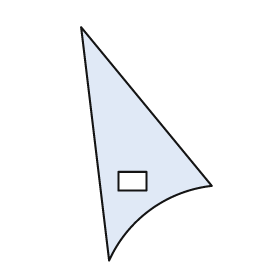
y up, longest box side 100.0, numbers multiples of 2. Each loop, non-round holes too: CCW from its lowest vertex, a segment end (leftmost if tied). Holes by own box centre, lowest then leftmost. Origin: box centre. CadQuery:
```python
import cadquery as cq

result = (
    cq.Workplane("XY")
    .moveTo(-16.0, -50.0)
    .threePointArc((2.0, -28.0), (28.0, -18.0))
    .lineTo(-28.0, 50.0)
    .close()
    .moveTo(-12.0, -20.0)
    .lineTo(0.0, -20.0)
    .lineTo(0.0, -12.0)
    .lineTo(-12.0, -12.0)
    .close()
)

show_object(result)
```